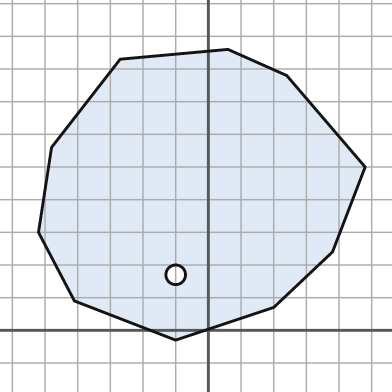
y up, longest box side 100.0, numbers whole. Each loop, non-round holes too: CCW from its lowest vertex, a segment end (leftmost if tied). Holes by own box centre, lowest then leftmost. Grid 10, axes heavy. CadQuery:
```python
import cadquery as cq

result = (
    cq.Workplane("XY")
    .moveTo(-10.0, -3.0)
    .lineTo(20.0, 7.0)
    .lineTo(38.0, 24.0)
    .lineTo(48.0, 50.0)
    .lineTo(24.0, 78.0)
    .lineTo(6.0, 86.0)
    .lineTo(-27.0, 83.0)
    .lineTo(-48.0, 56.0)
    .lineTo(-52.0, 30.0)
    .lineTo(-41.0, 9.0)
    .close()
    .moveTo(-10.0, 17.0)
    .circle(3.0)
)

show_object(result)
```